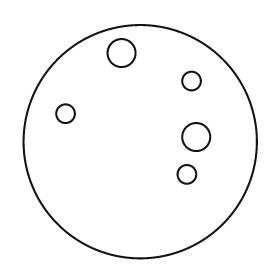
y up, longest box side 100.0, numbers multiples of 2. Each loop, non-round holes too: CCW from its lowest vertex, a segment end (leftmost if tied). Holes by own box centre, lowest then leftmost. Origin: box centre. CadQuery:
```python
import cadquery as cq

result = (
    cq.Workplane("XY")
    .moveTo(0.0, 0.0)
    .circle(50.0)
    .moveTo(20.0, -14.0)
    .circle(4.0)
    .moveTo(24.0, 2.0)
    .circle(6.0)
    .moveTo(-32.0, 12.0)
    .circle(4.0)
    .moveTo(22.0, 26.0)
    .circle(4.0)
    .moveTo(-8.0, 38.0)
    .circle(6.0)
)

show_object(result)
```